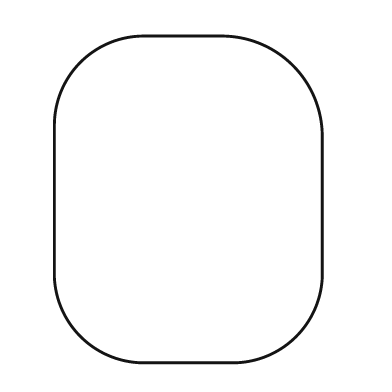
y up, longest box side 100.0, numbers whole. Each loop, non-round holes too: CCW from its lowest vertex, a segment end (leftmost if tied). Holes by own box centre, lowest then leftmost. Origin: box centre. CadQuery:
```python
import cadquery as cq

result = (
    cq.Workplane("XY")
    .moveTo(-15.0, -50.0)
    .lineTo(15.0, -50.0)
    .threePointArc((33.0, -42.0), (41.0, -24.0))
    .lineTo(41.0, 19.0)
    .threePointArc((32.0, 41.0), (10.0, 50.0))
    .lineTo(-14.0, 50.0)
    .threePointArc((-33.0, 42.0), (-41.0, 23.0))
    .lineTo(-41.0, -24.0)
    .threePointArc((-33.0, -42.0), (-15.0, -50.0))
    .close()
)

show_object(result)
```